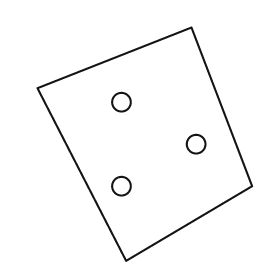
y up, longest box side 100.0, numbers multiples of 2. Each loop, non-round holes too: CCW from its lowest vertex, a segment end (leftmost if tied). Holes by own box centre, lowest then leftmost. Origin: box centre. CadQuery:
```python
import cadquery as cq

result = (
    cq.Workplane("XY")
    .moveTo(-8.0, -50.0)
    .lineTo(46.0, -18.0)
    .lineTo(20.0, 50.0)
    .lineTo(-46.0, 24.0)
    .close()
    .moveTo(-10.0, -18.0)
    .circle(4.0)
    .moveTo(22.0, 0.0)
    .circle(4.0)
    .moveTo(-10.0, 18.0)
    .circle(4.0)
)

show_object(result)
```